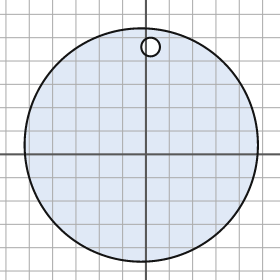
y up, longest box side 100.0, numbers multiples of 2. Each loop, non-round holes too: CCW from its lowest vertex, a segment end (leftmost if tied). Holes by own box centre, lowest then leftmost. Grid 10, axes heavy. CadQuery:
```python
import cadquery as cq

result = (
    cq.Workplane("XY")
    .moveTo(-2.0, 4.0)
    .circle(50.0)
    .moveTo(2.0, 46.0)
    .circle(4.0)
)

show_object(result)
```